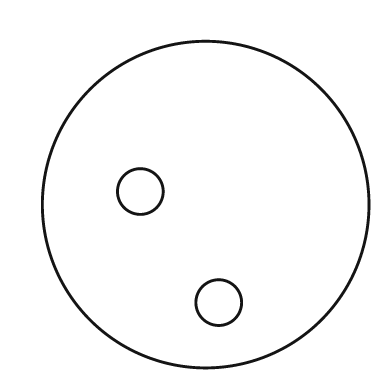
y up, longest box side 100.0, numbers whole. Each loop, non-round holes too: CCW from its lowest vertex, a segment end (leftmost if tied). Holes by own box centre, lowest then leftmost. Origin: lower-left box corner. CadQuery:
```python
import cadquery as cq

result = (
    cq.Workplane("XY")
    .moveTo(50.0, 50.0)
    .circle(50.0)
    .moveTo(54.0, 20.0)
    .circle(7.0)
    .moveTo(30.0, 54.0)
    .circle(7.0)
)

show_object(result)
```